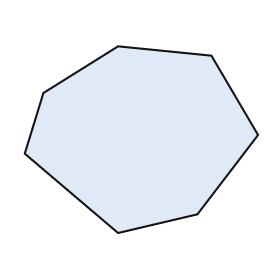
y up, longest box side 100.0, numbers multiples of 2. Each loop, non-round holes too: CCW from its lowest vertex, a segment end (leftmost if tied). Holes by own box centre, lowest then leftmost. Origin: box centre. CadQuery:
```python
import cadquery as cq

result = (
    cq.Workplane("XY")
    .moveTo(-10.0, -40.0)
    .lineTo(24.0, -32.0)
    .lineTo(50.0, 2.0)
    .lineTo(30.0, 36.0)
    .lineTo(-10.0, 40.0)
    .lineTo(-42.0, 20.0)
    .lineTo(-50.0, -6.0)
    .close()
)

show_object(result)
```